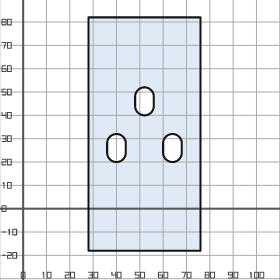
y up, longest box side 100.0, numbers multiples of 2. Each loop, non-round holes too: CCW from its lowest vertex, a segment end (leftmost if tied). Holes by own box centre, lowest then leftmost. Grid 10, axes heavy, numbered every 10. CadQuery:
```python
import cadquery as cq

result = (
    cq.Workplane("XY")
    .moveTo(28.0, -18.0)
    .lineTo(76.0, -18.0)
    .lineTo(76.0, 82.0)
    .lineTo(28.0, 82.0)
    .close()
    .moveTo(36.0, 24.0)
    .threePointArc((40.0, 20.0), (44.0, 24.0))
    .lineTo(44.0, 28.0)
    .threePointArc((40.0, 32.0), (36.0, 28.0))
    .close()
    .moveTo(60.0, 24.0)
    .threePointArc((64.0, 20.0), (68.0, 24.0))
    .lineTo(68.0, 28.0)
    .threePointArc((64.0, 32.0), (60.0, 28.0))
    .close()
    .moveTo(48.0, 44.0)
    .threePointArc((52.0, 40.0), (56.0, 44.0))
    .lineTo(56.0, 48.0)
    .threePointArc((52.0, 52.0), (48.0, 48.0))
    .close()
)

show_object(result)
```